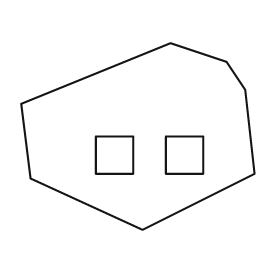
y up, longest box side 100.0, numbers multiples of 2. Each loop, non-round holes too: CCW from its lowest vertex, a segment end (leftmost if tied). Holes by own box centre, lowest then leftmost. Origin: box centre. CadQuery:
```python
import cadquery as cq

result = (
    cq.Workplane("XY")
    .moveTo(2.0, -40.0)
    .lineTo(50.0, -16.0)
    .lineTo(46.0, 20.0)
    .lineTo(38.0, 32.0)
    .lineTo(14.0, 40.0)
    .lineTo(-50.0, 14.0)
    .lineTo(-46.0, -18.0)
    .close()
    .moveTo(-18.0, -16.0)
    .lineTo(-2.0, -16.0)
    .lineTo(-2.0, 0.0)
    .lineTo(-18.0, 0.0)
    .close()
    .moveTo(12.0, -16.0)
    .lineTo(28.0, -16.0)
    .lineTo(28.0, 0.0)
    .lineTo(12.0, 0.0)
    .close()
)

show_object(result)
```